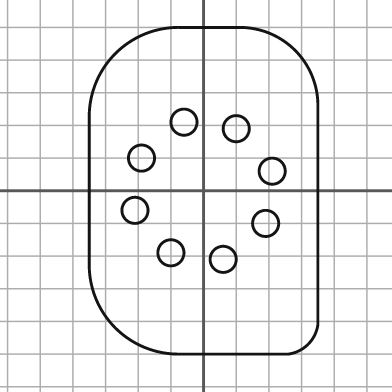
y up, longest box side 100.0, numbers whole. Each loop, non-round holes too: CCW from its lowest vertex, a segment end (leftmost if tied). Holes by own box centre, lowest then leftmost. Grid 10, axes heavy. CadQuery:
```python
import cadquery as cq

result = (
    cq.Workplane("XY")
    .moveTo(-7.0, -50.0)
    .lineTo(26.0, -50.0)
    .threePointArc((32.0, -47.0), (35.0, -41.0))
    .lineTo(35.0, 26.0)
    .threePointArc((28.0, 43.0), (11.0, 50.0))
    .lineTo(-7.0, 50.0)
    .threePointArc((-27.0, 42.0), (-35.0, 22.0))
    .lineTo(-35.0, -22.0)
    .threePointArc((-27.0, -42.0), (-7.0, -50.0))
    .close()
    .moveTo(6.0, -21.0)
    .circle(4.0)
    .moveTo(-10.0, -19.0)
    .circle(4.0)
    .moveTo(19.0, -10.0)
    .circle(4.0)
    .moveTo(-21.0, -6.0)
    .circle(4.0)
    .moveTo(21.0, 6.0)
    .circle(4.0)
    .moveTo(-19.0, 10.0)
    .circle(4.0)
    .moveTo(10.0, 19.0)
    .circle(4.0)
    .moveTo(-6.0, 21.0)
    .circle(4.0)
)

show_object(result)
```